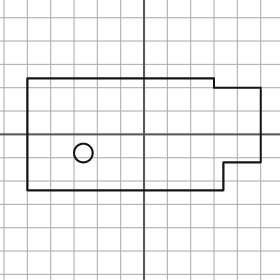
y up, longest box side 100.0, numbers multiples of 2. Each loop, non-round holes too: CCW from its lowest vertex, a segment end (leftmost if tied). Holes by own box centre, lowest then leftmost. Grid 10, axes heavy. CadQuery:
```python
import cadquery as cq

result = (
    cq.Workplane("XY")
    .moveTo(-50.0, -24.0)
    .lineTo(34.0, -24.0)
    .lineTo(34.0, -12.0)
    .lineTo(50.0, -12.0)
    .lineTo(50.0, 20.0)
    .lineTo(30.0, 20.0)
    .lineTo(30.0, 24.0)
    .lineTo(-50.0, 24.0)
    .close()
    .moveTo(-26.0, -8.0)
    .circle(4.0)
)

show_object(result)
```